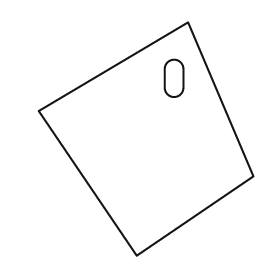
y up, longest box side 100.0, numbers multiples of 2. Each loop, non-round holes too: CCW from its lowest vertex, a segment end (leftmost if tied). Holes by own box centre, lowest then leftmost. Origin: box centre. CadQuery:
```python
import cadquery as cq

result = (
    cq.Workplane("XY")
    .moveTo(-4.0, -50.0)
    .lineTo(46.0, -16.0)
    .lineTo(18.0, 50.0)
    .lineTo(-46.0, 12.0)
    .close()
    .moveTo(8.0, 22.0)
    .threePointArc((12.0, 18.0), (16.0, 22.0))
    .lineTo(16.0, 30.0)
    .threePointArc((12.0, 34.0), (8.0, 30.0))
    .close()
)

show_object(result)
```